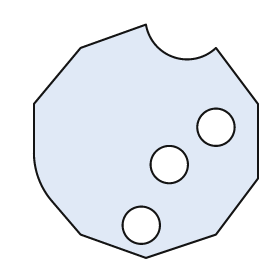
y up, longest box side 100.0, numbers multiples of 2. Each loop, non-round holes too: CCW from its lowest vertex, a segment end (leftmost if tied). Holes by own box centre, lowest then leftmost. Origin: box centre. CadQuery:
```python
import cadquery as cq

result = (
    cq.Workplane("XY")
    .moveTo(0.0, -50.0)
    .lineTo(30.0, -40.0)
    .lineTo(48.0, -16.0)
    .lineTo(48.0, 16.0)
    .lineTo(30.0, 40.0)
    .threePointArc((12.0, 36.0), (0.0, 50.0))
    .lineTo(-28.0, 40.0)
    .lineTo(-48.0, 16.0)
    .lineTo(-48.0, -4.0)
    .threePointArc((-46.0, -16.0), (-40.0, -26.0))
    .lineTo(-28.0, -40.0)
    .close()
    .moveTo(-2.0, -36.0)
    .circle(8.0)
    .moveTo(10.0, -10.0)
    .circle(8.0)
    .moveTo(30.0, 6.0)
    .circle(8.0)
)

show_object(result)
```